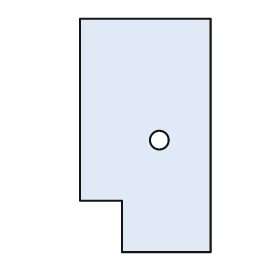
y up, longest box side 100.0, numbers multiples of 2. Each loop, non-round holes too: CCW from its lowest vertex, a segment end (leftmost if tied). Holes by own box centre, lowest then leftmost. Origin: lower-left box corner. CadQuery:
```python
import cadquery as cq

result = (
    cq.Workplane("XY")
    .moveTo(18.0, 0.0)
    .lineTo(56.0, 0.0)
    .lineTo(56.0, 100.0)
    .lineTo(0.0, 100.0)
    .lineTo(0.0, 22.0)
    .lineTo(18.0, 22.0)
    .close()
    .moveTo(34.0, 48.0)
    .circle(4.0)
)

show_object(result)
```